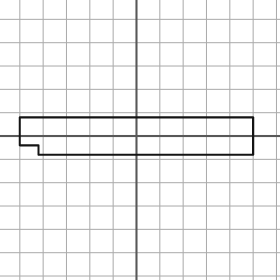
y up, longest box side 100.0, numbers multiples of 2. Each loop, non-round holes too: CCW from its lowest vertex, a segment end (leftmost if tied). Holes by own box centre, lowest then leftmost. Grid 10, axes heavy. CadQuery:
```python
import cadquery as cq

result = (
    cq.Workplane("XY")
    .moveTo(-42.0, -8.0)
    .lineTo(50.0, -8.0)
    .lineTo(50.0, 8.0)
    .lineTo(-50.0, 8.0)
    .lineTo(-50.0, -4.0)
    .lineTo(-42.0, -4.0)
    .close()
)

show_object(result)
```